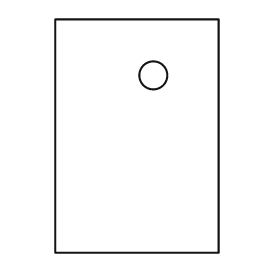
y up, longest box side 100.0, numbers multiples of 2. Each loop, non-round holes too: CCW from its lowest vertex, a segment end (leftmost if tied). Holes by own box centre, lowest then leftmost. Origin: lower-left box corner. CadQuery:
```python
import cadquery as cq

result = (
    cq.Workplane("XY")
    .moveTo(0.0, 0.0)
    .lineTo(70.0, 0.0)
    .lineTo(70.0, 100.0)
    .lineTo(0.0, 100.0)
    .close()
    .moveTo(42.0, 76.0)
    .circle(6.0)
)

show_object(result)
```